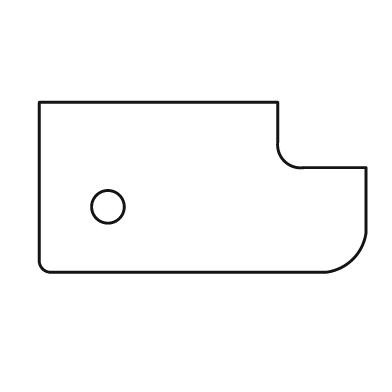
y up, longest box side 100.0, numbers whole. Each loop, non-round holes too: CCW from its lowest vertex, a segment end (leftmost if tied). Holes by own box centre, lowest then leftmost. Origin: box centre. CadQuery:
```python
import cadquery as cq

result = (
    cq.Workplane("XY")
    .moveTo(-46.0, -26.0)
    .lineTo(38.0, -26.0)
    .threePointArc((46.0, -22.0), (50.0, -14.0))
    .lineTo(50.0, 6.0)
    .lineTo(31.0, 6.0)
    .threePointArc((25.0, 8.0), (23.0, 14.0))
    .lineTo(23.0, 26.0)
    .lineTo(-50.0, 26.0)
    .lineTo(-50.0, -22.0)
    .threePointArc((-49.0, -25.0), (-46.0, -26.0))
    .close()
    .moveTo(-29.0, -6.0)
    .circle(5.0)
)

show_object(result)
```